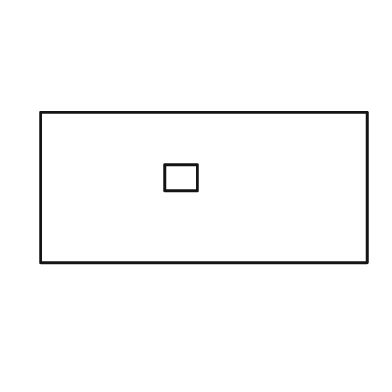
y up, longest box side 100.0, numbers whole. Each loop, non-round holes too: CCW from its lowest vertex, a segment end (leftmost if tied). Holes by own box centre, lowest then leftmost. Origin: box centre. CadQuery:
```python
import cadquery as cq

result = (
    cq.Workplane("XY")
    .moveTo(-50.0, -23.0)
    .lineTo(50.0, -23.0)
    .lineTo(50.0, 23.0)
    .lineTo(-50.0, 23.0)
    .close()
    .moveTo(-12.0, -1.0)
    .lineTo(-2.0, -1.0)
    .lineTo(-2.0, 7.0)
    .lineTo(-12.0, 7.0)
    .close()
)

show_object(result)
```